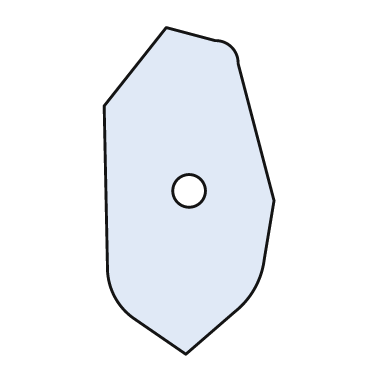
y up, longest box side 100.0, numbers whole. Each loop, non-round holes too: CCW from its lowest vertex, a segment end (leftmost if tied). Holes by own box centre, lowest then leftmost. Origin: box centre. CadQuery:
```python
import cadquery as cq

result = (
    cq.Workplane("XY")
    .moveTo(-1.0, -50.0)
    .lineTo(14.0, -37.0)
    .threePointArc((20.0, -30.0), (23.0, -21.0))
    .lineTo(26.0, -3.0)
    .lineTo(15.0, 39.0)
    .threePointArc((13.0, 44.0), (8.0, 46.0))
    .lineTo(-7.0, 50.0)
    .lineTo(-26.0, 26.0)
    .lineTo(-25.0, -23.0)
    .threePointArc((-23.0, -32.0), (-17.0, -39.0))
    .close()
    .moveTo(0.0, 0.0)
    .circle(5.0)
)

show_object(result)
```